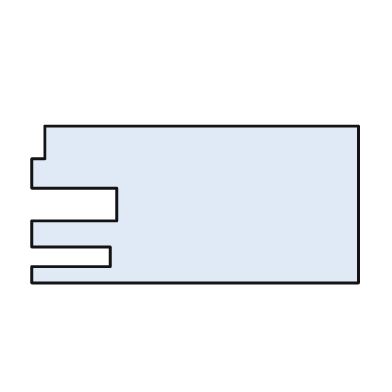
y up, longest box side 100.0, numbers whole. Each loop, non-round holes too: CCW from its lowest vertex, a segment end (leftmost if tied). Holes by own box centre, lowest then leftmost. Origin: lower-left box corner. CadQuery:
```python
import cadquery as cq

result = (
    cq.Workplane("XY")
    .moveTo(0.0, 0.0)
    .lineTo(100.0, 0.0)
    .lineTo(100.0, 48.0)
    .lineTo(4.0, 48.0)
    .lineTo(4.0, 38.0)
    .lineTo(0.0, 38.0)
    .lineTo(0.0, 29.0)
    .lineTo(26.0, 29.0)
    .lineTo(26.0, 19.0)
    .lineTo(0.0, 19.0)
    .lineTo(0.0, 11.0)
    .lineTo(24.0, 11.0)
    .lineTo(24.0, 5.0)
    .lineTo(0.0, 5.0)
    .close()
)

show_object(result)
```